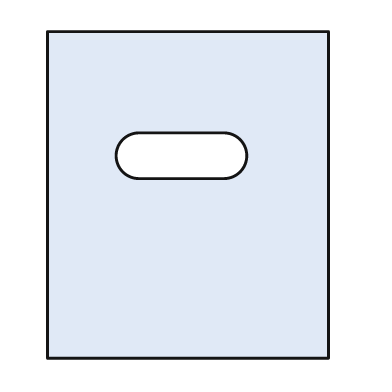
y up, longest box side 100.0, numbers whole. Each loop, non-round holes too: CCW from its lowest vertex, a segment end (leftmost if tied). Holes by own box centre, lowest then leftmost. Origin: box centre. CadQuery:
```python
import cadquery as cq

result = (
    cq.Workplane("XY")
    .moveTo(-43.0, -50.0)
    .lineTo(43.0, -50.0)
    .lineTo(43.0, 50.0)
    .lineTo(-43.0, 50.0)
    .close()
    .moveTo(-15.0, 5.0)
    .lineTo(11.0, 5.0)
    .threePointArc((18.0, 12.0), (11.0, 19.0))
    .lineTo(-15.0, 19.0)
    .threePointArc((-22.0, 12.0), (-15.0, 5.0))
    .close()
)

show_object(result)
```